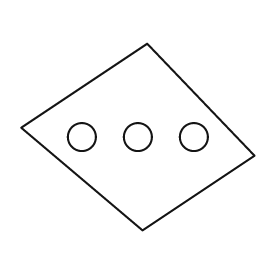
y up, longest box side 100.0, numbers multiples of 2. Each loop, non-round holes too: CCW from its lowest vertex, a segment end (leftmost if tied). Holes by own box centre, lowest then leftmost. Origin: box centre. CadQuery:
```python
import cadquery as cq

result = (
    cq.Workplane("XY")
    .moveTo(2.0, -40.0)
    .lineTo(50.0, -8.0)
    .lineTo(4.0, 40.0)
    .lineTo(-50.0, 4.0)
    .close()
    .moveTo(-24.0, 0.0)
    .circle(6.0)
    .moveTo(0.0, 0.0)
    .circle(6.0)
    .moveTo(24.0, 0.0)
    .circle(6.0)
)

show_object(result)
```